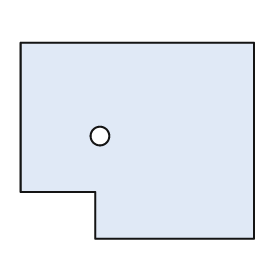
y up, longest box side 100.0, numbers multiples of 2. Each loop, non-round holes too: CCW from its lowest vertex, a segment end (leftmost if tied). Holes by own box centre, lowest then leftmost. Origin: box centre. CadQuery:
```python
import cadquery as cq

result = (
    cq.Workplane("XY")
    .moveTo(-18.0, -42.0)
    .lineTo(50.0, -42.0)
    .lineTo(50.0, 42.0)
    .lineTo(-50.0, 42.0)
    .lineTo(-50.0, -22.0)
    .lineTo(-18.0, -22.0)
    .close()
    .moveTo(-16.0, 2.0)
    .circle(4.0)
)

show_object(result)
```